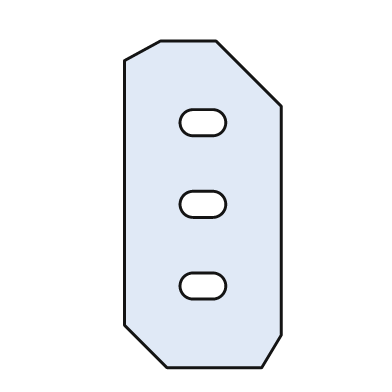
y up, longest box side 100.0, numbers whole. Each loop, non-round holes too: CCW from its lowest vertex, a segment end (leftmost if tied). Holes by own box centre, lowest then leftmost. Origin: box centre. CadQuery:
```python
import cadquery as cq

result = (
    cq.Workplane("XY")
    .moveTo(-11.0, -50.0)
    .lineTo(18.0, -50.0)
    .lineTo(24.0, -40.0)
    .lineTo(24.0, 30.0)
    .lineTo(4.0, 50.0)
    .lineTo(-13.0, 50.0)
    .lineTo(-24.0, 44.0)
    .lineTo(-24.0, -37.0)
    .close()
    .moveTo(-3.0, -29.0)
    .lineTo(3.0, -29.0)
    .threePointArc((7.0, -25.0), (3.0, -21.0))
    .lineTo(-3.0, -21.0)
    .threePointArc((-7.0, -25.0), (-3.0, -29.0))
    .close()
    .moveTo(-3.0, -4.0)
    .lineTo(3.0, -4.0)
    .threePointArc((7.0, 0.0), (3.0, 4.0))
    .lineTo(-3.0, 4.0)
    .threePointArc((-7.0, 0.0), (-3.0, -4.0))
    .close()
    .moveTo(-3.0, 21.0)
    .lineTo(3.0, 21.0)
    .threePointArc((7.0, 25.0), (3.0, 29.0))
    .lineTo(-3.0, 29.0)
    .threePointArc((-7.0, 25.0), (-3.0, 21.0))
    .close()
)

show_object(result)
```